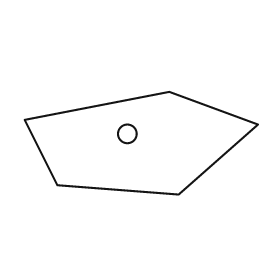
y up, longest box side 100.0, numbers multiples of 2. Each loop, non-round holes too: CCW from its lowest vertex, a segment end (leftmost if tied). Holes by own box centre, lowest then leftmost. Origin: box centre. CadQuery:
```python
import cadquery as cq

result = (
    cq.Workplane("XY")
    .moveTo(16.0, -22.0)
    .lineTo(50.0, 8.0)
    .lineTo(12.0, 22.0)
    .lineTo(-50.0, 10.0)
    .lineTo(-36.0, -18.0)
    .close()
    .moveTo(-6.0, 4.0)
    .circle(4.0)
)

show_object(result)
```